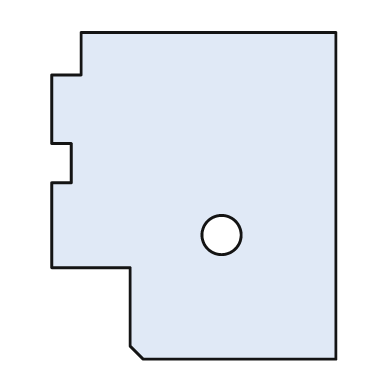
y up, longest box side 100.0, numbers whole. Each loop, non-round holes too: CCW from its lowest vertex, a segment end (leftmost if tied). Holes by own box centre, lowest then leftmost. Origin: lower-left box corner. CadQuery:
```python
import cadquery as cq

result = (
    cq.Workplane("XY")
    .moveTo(28.0, 0.0)
    .lineTo(87.0, 0.0)
    .lineTo(87.0, 100.0)
    .lineTo(9.0, 100.0)
    .lineTo(9.0, 87.0)
    .lineTo(0.0, 87.0)
    .lineTo(0.0, 66.0)
    .lineTo(6.0, 66.0)
    .lineTo(6.0, 54.0)
    .lineTo(0.0, 54.0)
    .lineTo(0.0, 28.0)
    .lineTo(24.0, 28.0)
    .lineTo(24.0, 4.0)
    .close()
    .moveTo(52.0, 38.0)
    .circle(6.0)
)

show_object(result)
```